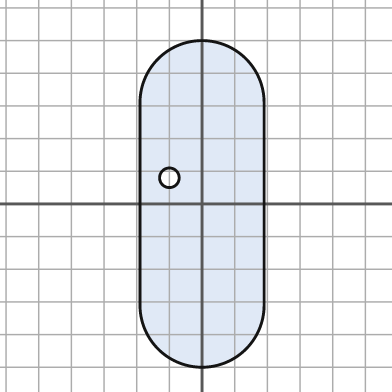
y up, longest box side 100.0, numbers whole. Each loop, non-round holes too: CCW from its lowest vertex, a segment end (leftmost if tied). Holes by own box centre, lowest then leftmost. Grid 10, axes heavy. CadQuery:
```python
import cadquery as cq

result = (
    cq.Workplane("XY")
    .moveTo(-19.0, -31.0)
    .threePointArc((0.0, -50.0), (19.0, -31.0))
    .lineTo(19.0, 31.0)
    .threePointArc((0.0, 50.0), (-19.0, 31.0))
    .close()
    .moveTo(-10.0, 8.0)
    .circle(3.0)
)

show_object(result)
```